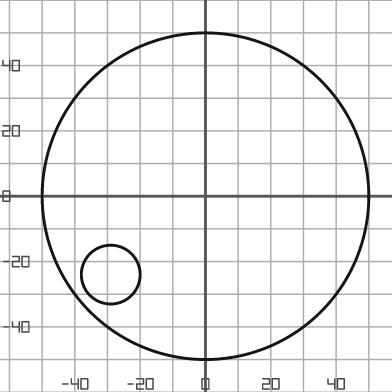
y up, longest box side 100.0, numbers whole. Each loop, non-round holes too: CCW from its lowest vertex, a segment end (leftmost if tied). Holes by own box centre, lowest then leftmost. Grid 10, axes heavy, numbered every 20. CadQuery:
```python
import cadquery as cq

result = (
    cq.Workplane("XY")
    .moveTo(0.0, 0.0)
    .circle(50.0)
    .moveTo(-29.0, -24.0)
    .circle(9.0)
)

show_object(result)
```